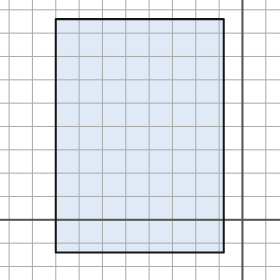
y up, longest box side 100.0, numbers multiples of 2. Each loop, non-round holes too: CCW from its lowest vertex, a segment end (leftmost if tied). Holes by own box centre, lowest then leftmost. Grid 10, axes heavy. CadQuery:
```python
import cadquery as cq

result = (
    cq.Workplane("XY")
    .moveTo(-80.0, -14.0)
    .lineTo(-8.0, -14.0)
    .lineTo(-8.0, 86.0)
    .lineTo(-80.0, 86.0)
    .close()
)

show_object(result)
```